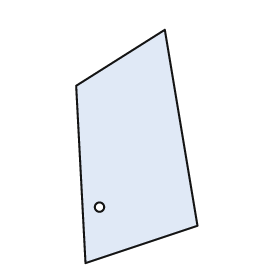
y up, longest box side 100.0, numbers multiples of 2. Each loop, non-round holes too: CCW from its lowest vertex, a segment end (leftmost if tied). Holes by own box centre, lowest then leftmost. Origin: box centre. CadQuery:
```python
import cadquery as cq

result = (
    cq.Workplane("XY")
    .moveTo(-22.0, -50.0)
    .lineTo(26.0, -34.0)
    .lineTo(12.0, 50.0)
    .lineTo(-26.0, 26.0)
    .close()
    .moveTo(-16.0, -26.0)
    .circle(2.0)
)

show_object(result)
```